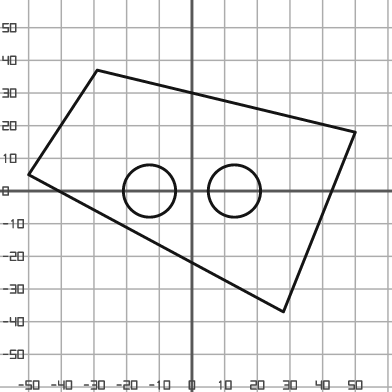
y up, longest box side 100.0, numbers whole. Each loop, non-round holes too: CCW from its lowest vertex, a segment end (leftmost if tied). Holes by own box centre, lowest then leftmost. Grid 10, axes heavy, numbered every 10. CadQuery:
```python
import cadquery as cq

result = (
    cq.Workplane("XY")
    .moveTo(28.0, -37.0)
    .lineTo(50.0, 18.0)
    .lineTo(-29.0, 37.0)
    .lineTo(-50.0, 5.0)
    .close()
    .moveTo(-13.0, 0.0)
    .circle(8.0)
    .moveTo(13.0, 0.0)
    .circle(8.0)
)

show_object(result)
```